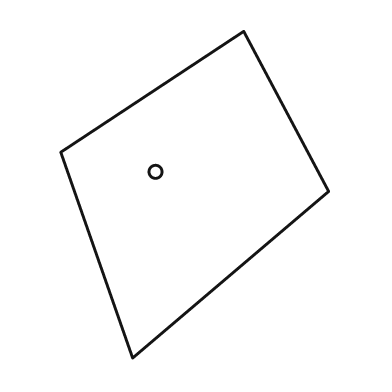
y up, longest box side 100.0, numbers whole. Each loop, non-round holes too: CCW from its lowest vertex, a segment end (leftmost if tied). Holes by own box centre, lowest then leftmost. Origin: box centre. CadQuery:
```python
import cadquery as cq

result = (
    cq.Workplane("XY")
    .moveTo(-19.0, -50.0)
    .lineTo(41.0, 1.0)
    .lineTo(15.0, 50.0)
    .lineTo(-41.0, 13.0)
    .close()
    .moveTo(-12.0, 7.0)
    .circle(2.0)
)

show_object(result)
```